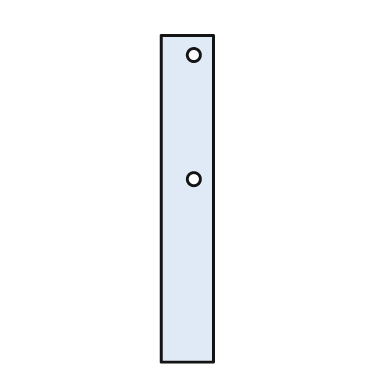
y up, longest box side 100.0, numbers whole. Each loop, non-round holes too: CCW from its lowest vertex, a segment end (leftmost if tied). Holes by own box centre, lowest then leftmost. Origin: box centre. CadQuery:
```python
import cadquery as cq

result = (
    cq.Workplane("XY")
    .moveTo(-8.0, -50.0)
    .lineTo(8.0, -50.0)
    .lineTo(8.0, 50.0)
    .lineTo(-8.0, 50.0)
    .close()
    .moveTo(2.0, 6.0)
    .circle(2.0)
    .moveTo(2.0, 44.0)
    .circle(2.0)
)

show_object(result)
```